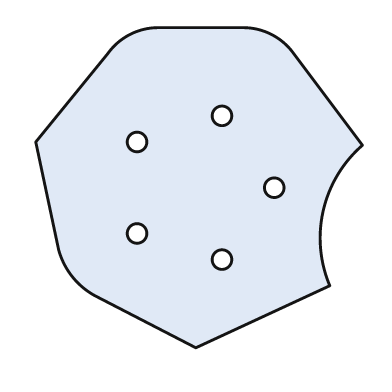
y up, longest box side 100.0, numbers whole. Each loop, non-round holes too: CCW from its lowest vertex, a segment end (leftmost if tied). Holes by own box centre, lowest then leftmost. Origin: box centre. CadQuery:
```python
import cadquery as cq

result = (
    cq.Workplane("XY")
    .moveTo(-1.0, -49.0)
    .lineTo(40.0, -30.0)
    .threePointArc((38.0, -7.0), (50.0, 13.0))
    .lineTo(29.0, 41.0)
    .threePointArc((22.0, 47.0), (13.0, 49.0))
    .lineTo(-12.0, 49.0)
    .threePointArc((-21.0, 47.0), (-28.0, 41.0))
    .lineTo(-50.0, 14.0)
    .lineTo(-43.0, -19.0)
    .threePointArc((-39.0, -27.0), (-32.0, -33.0))
    .close()
    .moveTo(7.0, -22.0)
    .circle(3.0)
    .moveTo(-19.0, -14.0)
    .circle(3.0)
    .moveTo(23.0, 0.0)
    .circle(3.0)
    .moveTo(-19.0, 14.0)
    .circle(3.0)
    .moveTo(7.0, 22.0)
    .circle(3.0)
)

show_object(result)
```